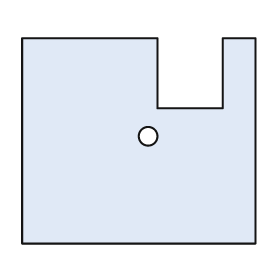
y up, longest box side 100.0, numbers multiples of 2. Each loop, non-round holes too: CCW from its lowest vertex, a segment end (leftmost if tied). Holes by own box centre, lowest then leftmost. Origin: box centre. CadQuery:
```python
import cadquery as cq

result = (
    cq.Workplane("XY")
    .moveTo(-50.0, -44.0)
    .lineTo(50.0, -44.0)
    .lineTo(50.0, 44.0)
    .lineTo(36.0, 44.0)
    .lineTo(36.0, 14.0)
    .lineTo(8.0, 14.0)
    .lineTo(8.0, 44.0)
    .lineTo(-50.0, 44.0)
    .close()
    .moveTo(4.0, 2.0)
    .circle(4.0)
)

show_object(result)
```